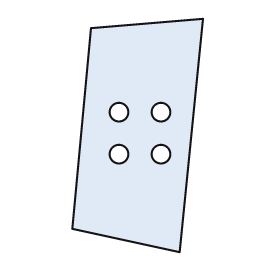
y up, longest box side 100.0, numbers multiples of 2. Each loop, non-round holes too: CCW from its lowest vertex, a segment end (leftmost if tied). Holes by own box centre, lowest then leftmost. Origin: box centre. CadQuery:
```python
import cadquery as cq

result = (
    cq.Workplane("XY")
    .moveTo(18.0, -50.0)
    .lineTo(28.0, 50.0)
    .lineTo(-20.0, 46.0)
    .lineTo(-28.0, -40.0)
    .close()
    .moveTo(-8.0, -8.0)
    .circle(4.0)
    .moveTo(10.0, -8.0)
    .circle(4.0)
    .moveTo(-8.0, 10.0)
    .circle(4.0)
    .moveTo(10.0, 10.0)
    .circle(4.0)
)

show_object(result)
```